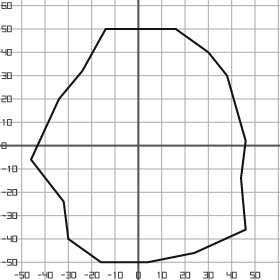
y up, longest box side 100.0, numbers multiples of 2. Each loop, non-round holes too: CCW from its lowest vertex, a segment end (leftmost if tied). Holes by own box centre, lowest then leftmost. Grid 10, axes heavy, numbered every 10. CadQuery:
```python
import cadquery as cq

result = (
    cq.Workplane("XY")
    .moveTo(-16.0, -50.0)
    .lineTo(4.0, -50.0)
    .lineTo(24.0, -46.0)
    .lineTo(46.0, -36.0)
    .lineTo(44.0, -14.0)
    .lineTo(46.0, 2.0)
    .lineTo(38.0, 30.0)
    .lineTo(30.0, 40.0)
    .lineTo(16.0, 50.0)
    .lineTo(-14.0, 50.0)
    .lineTo(-24.0, 32.0)
    .lineTo(-34.0, 20.0)
    .lineTo(-46.0, -6.0)
    .lineTo(-32.0, -24.0)
    .lineTo(-30.0, -40.0)
    .close()
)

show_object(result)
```